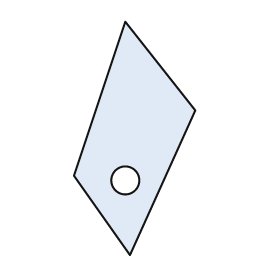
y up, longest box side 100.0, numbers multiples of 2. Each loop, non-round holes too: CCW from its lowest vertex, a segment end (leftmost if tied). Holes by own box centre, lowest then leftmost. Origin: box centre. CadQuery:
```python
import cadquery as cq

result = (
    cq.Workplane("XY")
    .moveTo(-2.0, -50.0)
    .lineTo(26.0, 12.0)
    .lineTo(-4.0, 50.0)
    .lineTo(-26.0, -16.0)
    .close()
    .moveTo(-4.0, -18.0)
    .circle(6.0)
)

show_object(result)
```